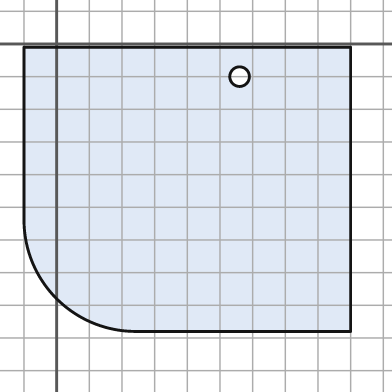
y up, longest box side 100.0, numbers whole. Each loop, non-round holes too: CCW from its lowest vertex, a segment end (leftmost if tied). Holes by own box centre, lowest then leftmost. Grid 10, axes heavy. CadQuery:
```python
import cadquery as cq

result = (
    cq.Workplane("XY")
    .moveTo(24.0, -88.0)
    .lineTo(90.0, -88.0)
    .lineTo(90.0, -1.0)
    .lineTo(-10.0, -1.0)
    .lineTo(-10.0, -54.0)
    .threePointArc((0.0, -78.0), (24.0, -88.0))
    .close()
    .moveTo(56.0, -10.0)
    .circle(3.0)
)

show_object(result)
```